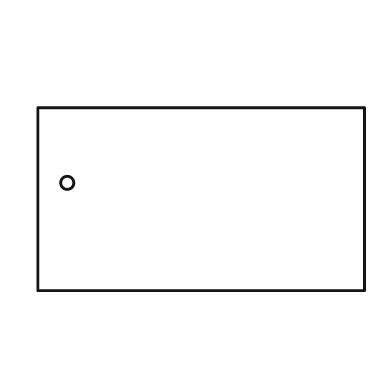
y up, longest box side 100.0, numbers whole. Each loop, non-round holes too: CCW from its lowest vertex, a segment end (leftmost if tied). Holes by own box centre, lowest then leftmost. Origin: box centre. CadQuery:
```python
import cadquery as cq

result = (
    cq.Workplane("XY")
    .moveTo(-50.0, -28.0)
    .lineTo(50.0, -28.0)
    .lineTo(50.0, 28.0)
    .lineTo(-50.0, 28.0)
    .close()
    .moveTo(-41.0, 5.0)
    .circle(2.0)
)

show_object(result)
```